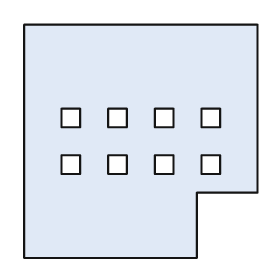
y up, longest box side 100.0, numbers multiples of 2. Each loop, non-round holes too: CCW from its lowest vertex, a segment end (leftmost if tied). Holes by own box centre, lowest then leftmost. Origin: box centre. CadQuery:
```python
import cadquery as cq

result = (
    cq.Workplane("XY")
    .moveTo(-50.0, -50.0)
    .lineTo(24.0, -50.0)
    .lineTo(24.0, -22.0)
    .lineTo(50.0, -22.0)
    .lineTo(50.0, 50.0)
    .lineTo(-50.0, 50.0)
    .close()
    .moveTo(-34.0, -14.0)
    .lineTo(-26.0, -14.0)
    .lineTo(-26.0, -6.0)
    .lineTo(-34.0, -6.0)
    .close()
    .moveTo(-14.0, -14.0)
    .lineTo(-6.0, -14.0)
    .lineTo(-6.0, -6.0)
    .lineTo(-14.0, -6.0)
    .close()
    .moveTo(6.0, -14.0)
    .lineTo(14.0, -14.0)
    .lineTo(14.0, -6.0)
    .lineTo(6.0, -6.0)
    .close()
    .moveTo(26.0, -14.0)
    .lineTo(34.0, -14.0)
    .lineTo(34.0, -6.0)
    .lineTo(26.0, -6.0)
    .close()
    .moveTo(-34.0, 6.0)
    .lineTo(-26.0, 6.0)
    .lineTo(-26.0, 14.0)
    .lineTo(-34.0, 14.0)
    .close()
    .moveTo(-14.0, 6.0)
    .lineTo(-6.0, 6.0)
    .lineTo(-6.0, 14.0)
    .lineTo(-14.0, 14.0)
    .close()
    .moveTo(6.0, 6.0)
    .lineTo(14.0, 6.0)
    .lineTo(14.0, 14.0)
    .lineTo(6.0, 14.0)
    .close()
    .moveTo(26.0, 6.0)
    .lineTo(34.0, 6.0)
    .lineTo(34.0, 14.0)
    .lineTo(26.0, 14.0)
    .close()
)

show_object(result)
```